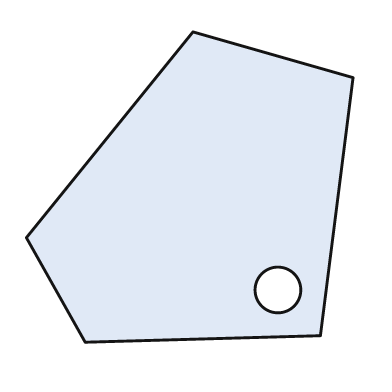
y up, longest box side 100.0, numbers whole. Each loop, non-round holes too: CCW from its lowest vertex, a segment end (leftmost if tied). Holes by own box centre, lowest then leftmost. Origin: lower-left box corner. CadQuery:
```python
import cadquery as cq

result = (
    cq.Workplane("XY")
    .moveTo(18.0, 0.0)
    .lineTo(90.0, 2.0)
    .lineTo(100.0, 81.0)
    .lineTo(51.0, 95.0)
    .lineTo(0.0, 32.0)
    .close()
    .moveTo(77.0, 16.0)
    .circle(7.0)
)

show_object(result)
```